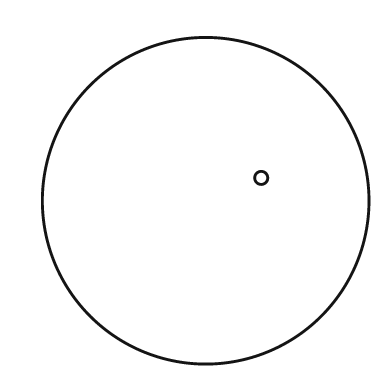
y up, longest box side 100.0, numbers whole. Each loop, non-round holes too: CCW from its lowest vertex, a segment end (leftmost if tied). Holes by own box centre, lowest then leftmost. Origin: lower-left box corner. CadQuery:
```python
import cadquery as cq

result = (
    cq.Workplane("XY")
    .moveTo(50.0, 50.0)
    .circle(50.0)
    .moveTo(67.0, 57.0)
    .circle(2.0)
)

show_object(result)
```